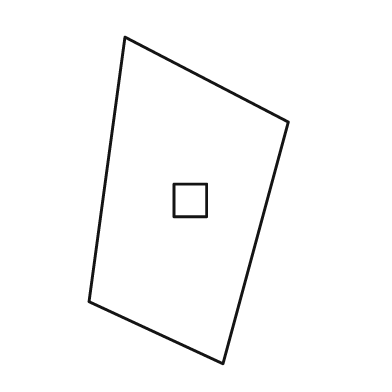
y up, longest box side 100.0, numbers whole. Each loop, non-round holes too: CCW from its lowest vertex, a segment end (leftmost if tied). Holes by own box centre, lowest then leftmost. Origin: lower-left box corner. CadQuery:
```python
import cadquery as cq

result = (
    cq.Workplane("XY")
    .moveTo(41.0, 0.0)
    .lineTo(61.0, 74.0)
    .lineTo(11.0, 100.0)
    .lineTo(0.0, 19.0)
    .close()
    .moveTo(26.0, 45.0)
    .lineTo(36.0, 45.0)
    .lineTo(36.0, 55.0)
    .lineTo(26.0, 55.0)
    .close()
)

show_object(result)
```